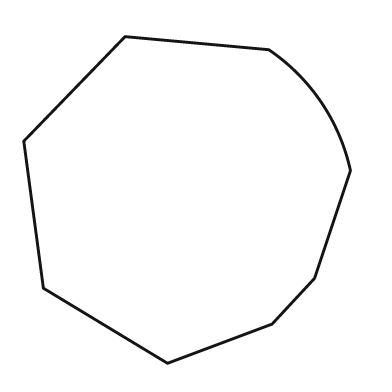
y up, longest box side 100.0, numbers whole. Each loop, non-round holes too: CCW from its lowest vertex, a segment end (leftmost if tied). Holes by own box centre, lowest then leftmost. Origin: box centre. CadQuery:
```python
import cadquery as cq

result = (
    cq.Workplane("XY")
    .moveTo(-6.0, -50.0)
    .lineTo(26.0, -38.0)
    .lineTo(39.0, -24.0)
    .lineTo(50.0, 9.0)
    .threePointArc((41.0, 30.0), (25.0, 46.0))
    .lineTo(-19.0, 50.0)
    .lineTo(-50.0, 18.0)
    .lineTo(-44.0, -27.0)
    .close()
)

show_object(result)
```